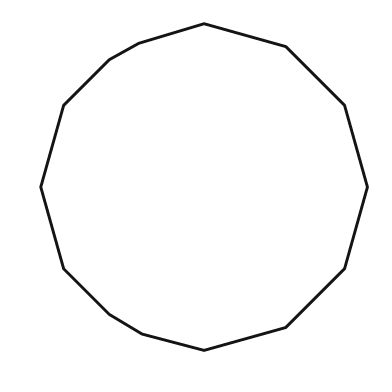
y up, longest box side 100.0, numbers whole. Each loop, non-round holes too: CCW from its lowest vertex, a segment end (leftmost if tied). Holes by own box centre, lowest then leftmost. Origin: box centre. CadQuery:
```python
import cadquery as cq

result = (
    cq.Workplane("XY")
    .moveTo(0.0, -50.0)
    .lineTo(25.0, -43.0)
    .lineTo(43.0, -25.0)
    .lineTo(50.0, 0.0)
    .lineTo(43.0, 25.0)
    .lineTo(25.0, 43.0)
    .lineTo(0.0, 50.0)
    .lineTo(-20.0, 44.0)
    .lineTo(-29.0, 39.0)
    .lineTo(-43.0, 25.0)
    .lineTo(-50.0, 0.0)
    .lineTo(-43.0, -25.0)
    .lineTo(-29.0, -39.0)
    .lineTo(-19.0, -45.0)
    .close()
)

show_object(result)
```